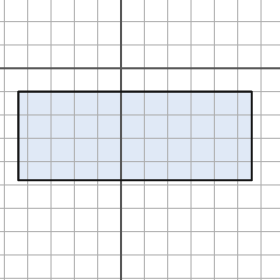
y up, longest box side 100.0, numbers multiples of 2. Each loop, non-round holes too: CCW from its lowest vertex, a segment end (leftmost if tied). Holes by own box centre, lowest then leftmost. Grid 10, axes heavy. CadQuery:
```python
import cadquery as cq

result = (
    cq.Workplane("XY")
    .moveTo(-44.0, -48.0)
    .lineTo(56.0, -48.0)
    .lineTo(56.0, -10.0)
    .lineTo(-44.0, -10.0)
    .close()
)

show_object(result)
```